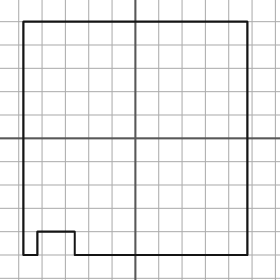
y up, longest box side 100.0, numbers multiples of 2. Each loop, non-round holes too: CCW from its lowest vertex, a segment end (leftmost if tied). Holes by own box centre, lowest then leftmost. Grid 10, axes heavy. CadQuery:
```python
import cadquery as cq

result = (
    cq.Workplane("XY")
    .moveTo(-48.0, -50.0)
    .lineTo(-42.0, -50.0)
    .lineTo(-42.0, -40.0)
    .lineTo(-26.0, -40.0)
    .lineTo(-26.0, -50.0)
    .lineTo(48.0, -50.0)
    .lineTo(48.0, 50.0)
    .lineTo(-48.0, 50.0)
    .close()
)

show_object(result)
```